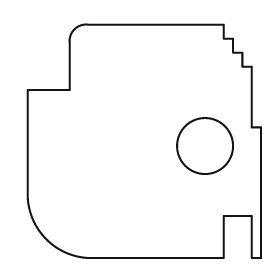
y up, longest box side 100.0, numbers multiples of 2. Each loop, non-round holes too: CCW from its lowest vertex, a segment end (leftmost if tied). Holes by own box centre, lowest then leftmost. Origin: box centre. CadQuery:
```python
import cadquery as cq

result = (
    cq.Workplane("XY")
    .moveTo(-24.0, -50.0)
    .lineTo(34.0, -50.0)
    .lineTo(34.0, -32.0)
    .lineTo(46.0, -32.0)
    .lineTo(46.0, -50.0)
    .lineTo(50.0, -50.0)
    .lineTo(50.0, 6.0)
    .lineTo(46.0, 6.0)
    .lineTo(46.0, 32.0)
    .lineTo(42.0, 32.0)
    .lineTo(42.0, 38.0)
    .lineTo(38.0, 38.0)
    .lineTo(38.0, 44.0)
    .lineTo(34.0, 44.0)
    .lineTo(34.0, 50.0)
    .lineTo(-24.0, 50.0)
    .threePointArc((-30.0, 48.0), (-32.0, 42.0))
    .lineTo(-32.0, 22.0)
    .lineTo(-50.0, 22.0)
    .lineTo(-50.0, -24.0)
    .threePointArc((-42.0, -42.0), (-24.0, -50.0))
    .close()
    .moveTo(26.0, -2.0)
    .circle(12.0)
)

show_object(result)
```